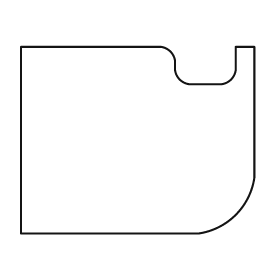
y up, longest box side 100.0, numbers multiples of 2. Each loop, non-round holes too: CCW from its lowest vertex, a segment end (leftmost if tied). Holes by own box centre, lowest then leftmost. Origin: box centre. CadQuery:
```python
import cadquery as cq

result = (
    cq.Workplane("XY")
    .moveTo(-50.0, -40.0)
    .lineTo(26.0, -40.0)
    .threePointArc((42.0, -32.0), (50.0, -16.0))
    .lineTo(50.0, 40.0)
    .lineTo(42.0, 40.0)
    .lineTo(42.0, 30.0)
    .threePointArc((40.0, 26.0), (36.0, 24.0))
    .lineTo(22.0, 24.0)
    .threePointArc((18.0, 26.0), (16.0, 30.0))
    .lineTo(16.0, 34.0)
    .threePointArc((14.0, 38.0), (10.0, 40.0))
    .lineTo(-50.0, 40.0)
    .close()
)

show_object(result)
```